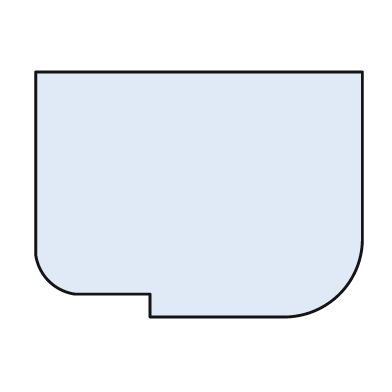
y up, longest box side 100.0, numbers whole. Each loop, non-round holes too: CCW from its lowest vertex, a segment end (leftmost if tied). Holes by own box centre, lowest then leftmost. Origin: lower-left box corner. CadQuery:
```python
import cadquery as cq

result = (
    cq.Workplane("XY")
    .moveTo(35.0, 0.0)
    .lineTo(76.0, 0.0)
    .threePointArc((93.0, 7.0), (100.0, 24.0))
    .lineTo(100.0, 75.0)
    .lineTo(0.0, 75.0)
    .lineTo(0.0, 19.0)
    .threePointArc((4.0, 11.0), (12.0, 7.0))
    .lineTo(35.0, 7.0)
    .close()
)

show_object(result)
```